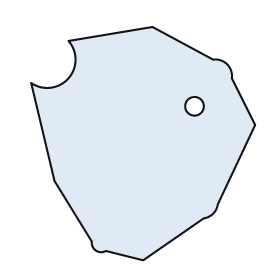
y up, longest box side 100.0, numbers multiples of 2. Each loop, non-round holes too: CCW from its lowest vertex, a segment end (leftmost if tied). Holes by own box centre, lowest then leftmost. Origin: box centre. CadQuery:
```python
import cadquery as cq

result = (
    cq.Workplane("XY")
    .moveTo(0.0, -50.0)
    .lineTo(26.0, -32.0)
    .threePointArc((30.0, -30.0), (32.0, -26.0))
    .lineTo(48.0, 8.0)
    .lineTo(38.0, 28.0)
    .threePointArc((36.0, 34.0), (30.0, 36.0))
    .lineTo(4.0, 50.0)
    .lineTo(-32.0, 44.0)
    .threePointArc((-32.0, 28.0), (-48.0, 26.0))
    .lineTo(-38.0, -16.0)
    .lineTo(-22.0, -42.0)
    .threePointArc((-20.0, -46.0), (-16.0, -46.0))
    .close()
    .moveTo(22.0, 16.0)
    .circle(4.0)
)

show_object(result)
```